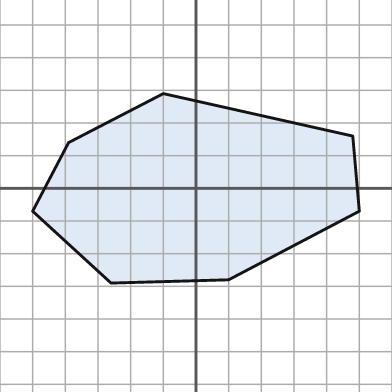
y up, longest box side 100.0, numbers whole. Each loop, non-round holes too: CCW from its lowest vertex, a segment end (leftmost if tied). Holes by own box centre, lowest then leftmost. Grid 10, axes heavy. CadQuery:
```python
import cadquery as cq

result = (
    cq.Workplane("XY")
    .moveTo(-26.0, -29.0)
    .lineTo(10.0, -28.0)
    .lineTo(50.0, -7.0)
    .lineTo(48.0, 16.0)
    .lineTo(-10.0, 29.0)
    .lineTo(-39.0, 14.0)
    .lineTo(-50.0, -7.0)
    .close()
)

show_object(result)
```